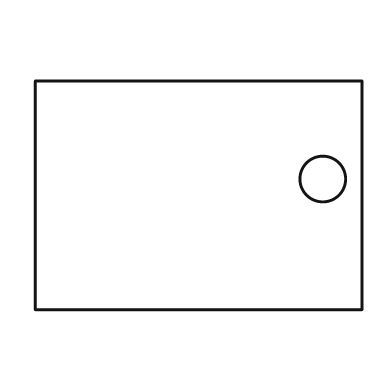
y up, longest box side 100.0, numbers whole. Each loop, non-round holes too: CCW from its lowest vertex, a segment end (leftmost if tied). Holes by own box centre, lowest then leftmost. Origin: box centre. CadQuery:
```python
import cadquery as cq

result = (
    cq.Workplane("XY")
    .moveTo(-50.0, -35.0)
    .lineTo(50.0, -35.0)
    .lineTo(50.0, 35.0)
    .lineTo(-50.0, 35.0)
    .close()
    .moveTo(38.0, 5.0)
    .circle(7.0)
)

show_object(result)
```